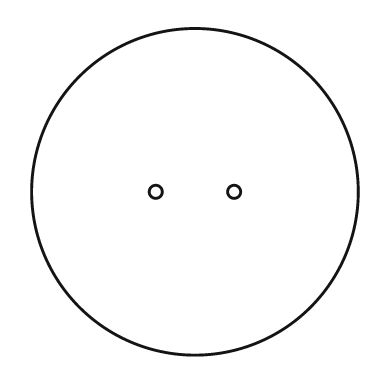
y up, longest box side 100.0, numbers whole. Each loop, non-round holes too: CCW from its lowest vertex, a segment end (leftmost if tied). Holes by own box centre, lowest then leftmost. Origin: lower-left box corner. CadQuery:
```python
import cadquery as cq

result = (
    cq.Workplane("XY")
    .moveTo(50.0, 50.0)
    .circle(50.0)
    .moveTo(38.0, 50.0)
    .circle(2.0)
    .moveTo(62.0, 50.0)
    .circle(2.0)
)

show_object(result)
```